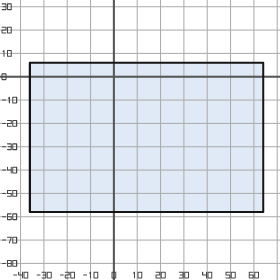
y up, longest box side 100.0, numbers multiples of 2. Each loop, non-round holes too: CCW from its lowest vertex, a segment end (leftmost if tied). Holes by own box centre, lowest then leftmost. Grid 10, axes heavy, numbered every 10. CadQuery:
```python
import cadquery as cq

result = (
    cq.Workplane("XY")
    .moveTo(-36.0, -58.0)
    .lineTo(64.0, -58.0)
    .lineTo(64.0, 6.0)
    .lineTo(-36.0, 6.0)
    .close()
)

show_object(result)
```